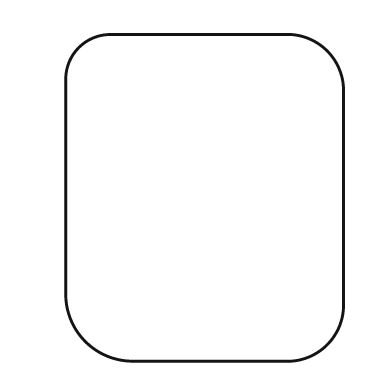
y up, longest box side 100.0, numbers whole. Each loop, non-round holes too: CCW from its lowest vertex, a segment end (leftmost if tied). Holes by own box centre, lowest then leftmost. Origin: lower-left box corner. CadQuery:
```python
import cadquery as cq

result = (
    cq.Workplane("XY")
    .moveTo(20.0, 0.0)
    .lineTo(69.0, 0.0)
    .threePointArc((80.0, 5.0), (85.0, 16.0))
    .lineTo(85.0, 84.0)
    .threePointArc((80.0, 95.0), (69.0, 100.0))
    .lineTo(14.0, 100.0)
    .threePointArc((4.0, 96.0), (0.0, 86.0))
    .lineTo(0.0, 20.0)
    .threePointArc((6.0, 6.0), (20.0, 0.0))
    .close()
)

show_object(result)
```